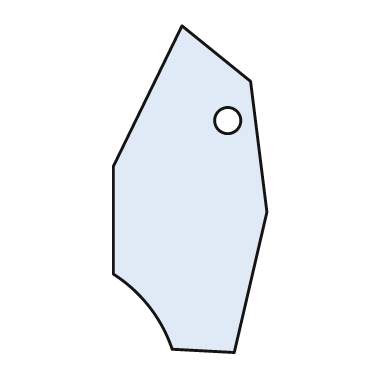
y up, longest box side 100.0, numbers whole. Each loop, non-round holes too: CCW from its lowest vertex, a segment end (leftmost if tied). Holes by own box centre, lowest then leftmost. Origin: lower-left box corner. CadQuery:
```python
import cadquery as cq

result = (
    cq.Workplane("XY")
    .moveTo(37.0, 0.0)
    .lineTo(47.0, 43.0)
    .lineTo(42.0, 83.0)
    .lineTo(21.0, 100.0)
    .lineTo(0.0, 57.0)
    .lineTo(0.0, 24.0)
    .threePointArc((11.0, 14.0), (18.0, 1.0))
    .close()
    .moveTo(35.0, 71.0)
    .circle(4.0)
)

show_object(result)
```